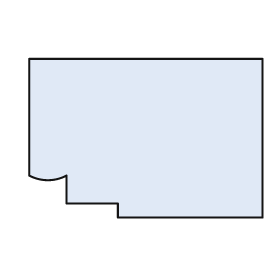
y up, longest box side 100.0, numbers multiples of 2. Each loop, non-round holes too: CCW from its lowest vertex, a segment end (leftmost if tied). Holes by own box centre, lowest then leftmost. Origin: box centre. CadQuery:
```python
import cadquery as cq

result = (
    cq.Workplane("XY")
    .moveTo(-12.0, -34.0)
    .lineTo(50.0, -34.0)
    .lineTo(50.0, 34.0)
    .lineTo(-50.0, 34.0)
    .lineTo(-50.0, -16.0)
    .threePointArc((-42.0, -18.0), (-34.0, -16.0))
    .lineTo(-34.0, -28.0)
    .lineTo(-12.0, -28.0)
    .close()
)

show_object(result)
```